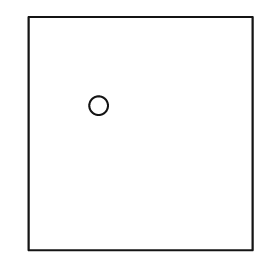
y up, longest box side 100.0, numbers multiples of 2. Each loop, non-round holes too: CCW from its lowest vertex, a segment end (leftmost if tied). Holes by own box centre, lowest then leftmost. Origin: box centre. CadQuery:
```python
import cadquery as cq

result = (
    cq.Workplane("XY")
    .moveTo(-48.0, -50.0)
    .lineTo(48.0, -50.0)
    .lineTo(48.0, 50.0)
    .lineTo(-48.0, 50.0)
    .close()
    .moveTo(-18.0, 12.0)
    .circle(4.0)
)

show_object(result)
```